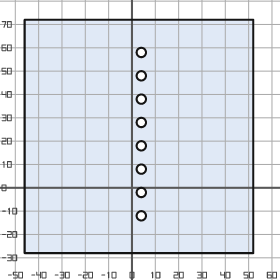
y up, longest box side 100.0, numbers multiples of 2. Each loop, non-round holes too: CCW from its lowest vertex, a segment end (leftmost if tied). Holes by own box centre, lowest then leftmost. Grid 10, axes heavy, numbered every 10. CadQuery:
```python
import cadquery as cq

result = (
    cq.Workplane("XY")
    .moveTo(-46.0, -28.0)
    .lineTo(52.0, -28.0)
    .lineTo(52.0, 72.0)
    .lineTo(-46.0, 72.0)
    .close()
    .moveTo(4.0, -12.0)
    .circle(2.0)
    .moveTo(4.0, -2.0)
    .circle(2.0)
    .moveTo(4.0, 8.0)
    .circle(2.0)
    .moveTo(4.0, 18.0)
    .circle(2.0)
    .moveTo(4.0, 28.0)
    .circle(2.0)
    .moveTo(4.0, 38.0)
    .circle(2.0)
    .moveTo(4.0, 48.0)
    .circle(2.0)
    .moveTo(4.0, 58.0)
    .circle(2.0)
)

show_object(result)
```